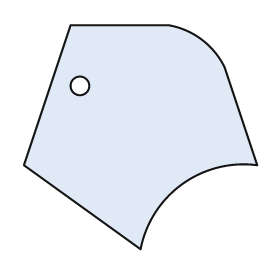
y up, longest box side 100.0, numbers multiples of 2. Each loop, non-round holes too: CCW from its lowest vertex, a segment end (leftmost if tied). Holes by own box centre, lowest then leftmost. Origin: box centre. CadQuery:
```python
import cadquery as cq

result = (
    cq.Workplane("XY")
    .moveTo(0.0, -48.0)
    .threePointArc((18.0, -20.0), (50.0, -12.0))
    .lineTo(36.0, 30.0)
    .threePointArc((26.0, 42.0), (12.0, 48.0))
    .lineTo(-30.0, 48.0)
    .lineTo(-50.0, -12.0)
    .close()
    .moveTo(-26.0, 22.0)
    .circle(4.0)
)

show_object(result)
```